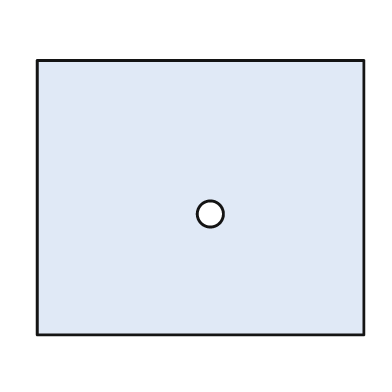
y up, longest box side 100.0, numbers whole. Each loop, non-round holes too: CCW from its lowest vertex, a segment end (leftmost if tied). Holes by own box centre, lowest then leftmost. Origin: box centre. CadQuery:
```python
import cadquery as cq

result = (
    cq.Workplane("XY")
    .moveTo(-50.0, -42.0)
    .lineTo(50.0, -42.0)
    .lineTo(50.0, 42.0)
    .lineTo(-50.0, 42.0)
    .close()
    .moveTo(3.0, -5.0)
    .circle(4.0)
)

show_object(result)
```